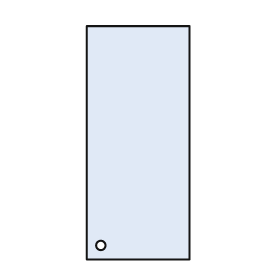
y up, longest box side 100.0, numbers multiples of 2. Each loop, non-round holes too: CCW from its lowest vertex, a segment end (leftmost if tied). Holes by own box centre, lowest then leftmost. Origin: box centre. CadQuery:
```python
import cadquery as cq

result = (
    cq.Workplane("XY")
    .moveTo(-22.0, -50.0)
    .lineTo(22.0, -50.0)
    .lineTo(22.0, 50.0)
    .lineTo(-22.0, 50.0)
    .close()
    .moveTo(-16.0, -44.0)
    .circle(2.0)
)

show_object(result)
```